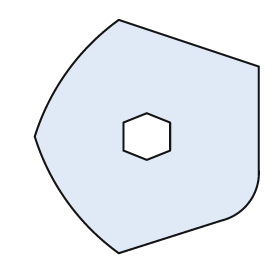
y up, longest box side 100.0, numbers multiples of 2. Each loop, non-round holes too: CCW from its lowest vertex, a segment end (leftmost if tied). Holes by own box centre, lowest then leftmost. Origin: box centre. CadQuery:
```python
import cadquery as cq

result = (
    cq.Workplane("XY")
    .moveTo(-12.0, -50.0)
    .lineTo(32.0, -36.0)
    .threePointArc((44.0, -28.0), (48.0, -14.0))
    .lineTo(48.0, 30.0)
    .lineTo(-12.0, 50.0)
    .threePointArc((-34.0, 28.0), (-48.0, 0.0))
    .threePointArc((-34.0, -28.0), (-12.0, -50.0))
    .close()
    .moveTo(0.0, -10.0)
    .lineTo(10.0, -6.0)
    .lineTo(10.0, 6.0)
    .lineTo(0.0, 10.0)
    .lineTo(-10.0, 6.0)
    .lineTo(-10.0, -6.0)
    .close()
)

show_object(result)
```